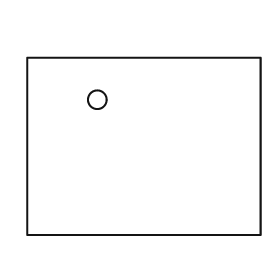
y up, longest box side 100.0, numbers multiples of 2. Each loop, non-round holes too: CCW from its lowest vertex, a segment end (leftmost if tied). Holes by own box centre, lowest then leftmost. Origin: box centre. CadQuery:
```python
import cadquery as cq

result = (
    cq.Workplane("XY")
    .moveTo(-50.0, -38.0)
    .lineTo(50.0, -38.0)
    .lineTo(50.0, 38.0)
    .lineTo(-50.0, 38.0)
    .close()
    .moveTo(-20.0, 20.0)
    .circle(4.0)
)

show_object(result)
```